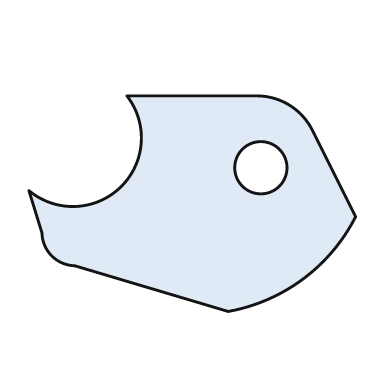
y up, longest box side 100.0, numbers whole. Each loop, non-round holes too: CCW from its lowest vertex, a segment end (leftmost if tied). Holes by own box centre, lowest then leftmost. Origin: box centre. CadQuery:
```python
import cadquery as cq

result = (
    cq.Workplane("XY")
    .moveTo(11.0, -33.0)
    .threePointArc((34.0, -23.0), (50.0, -4.0))
    .lineTo(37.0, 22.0)
    .threePointArc((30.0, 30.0), (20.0, 33.0))
    .lineTo(-20.0, 33.0)
    .threePointArc((-22.0, 5.0), (-50.0, 4.0))
    .lineTo(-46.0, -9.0)
    .threePointArc((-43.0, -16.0), (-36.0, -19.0))
    .close()
    .moveTo(21.0, 11.0)
    .circle(8.0)
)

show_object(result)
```